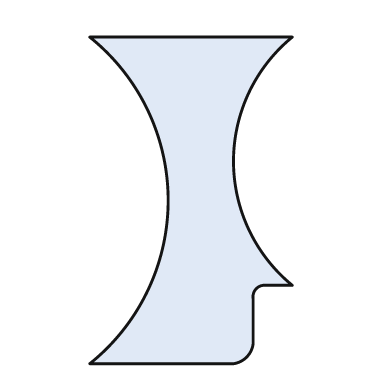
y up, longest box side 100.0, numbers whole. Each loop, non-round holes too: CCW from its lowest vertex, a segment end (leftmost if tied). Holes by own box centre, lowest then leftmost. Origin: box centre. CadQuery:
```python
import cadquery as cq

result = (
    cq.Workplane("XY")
    .moveTo(-31.0, -50.0)
    .lineTo(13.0, -50.0)
    .threePointArc((17.0, -48.0), (19.0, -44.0))
    .lineTo(19.0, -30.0)
    .threePointArc((20.0, -27.0), (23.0, -26.0))
    .lineTo(31.0, -26.0)
    .threePointArc((13.0, 12.0), (31.0, 50.0))
    .lineTo(-31.0, 50.0)
    .threePointArc((-7.0, 0.0), (-31.0, -50.0))
    .close()
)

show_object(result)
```